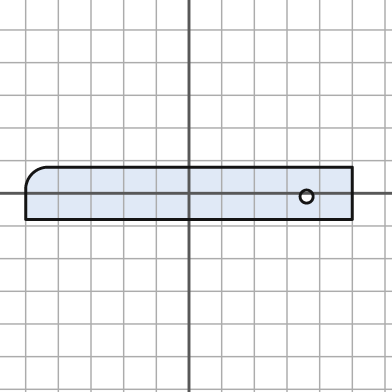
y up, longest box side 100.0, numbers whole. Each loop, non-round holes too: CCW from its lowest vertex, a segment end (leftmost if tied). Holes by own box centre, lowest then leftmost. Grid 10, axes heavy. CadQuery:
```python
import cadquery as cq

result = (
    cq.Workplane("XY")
    .moveTo(-50.0, -8.0)
    .lineTo(50.0, -8.0)
    .lineTo(50.0, 8.0)
    .lineTo(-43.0, 8.0)
    .threePointArc((-48.0, 6.0), (-50.0, 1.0))
    .close()
    .moveTo(36.0, -1.0)
    .circle(2.0)
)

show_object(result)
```